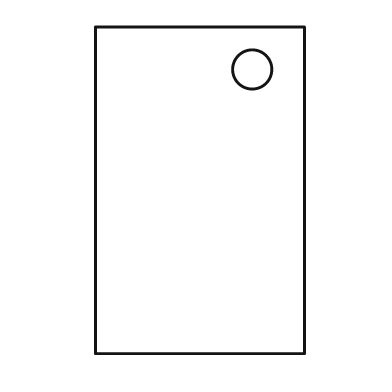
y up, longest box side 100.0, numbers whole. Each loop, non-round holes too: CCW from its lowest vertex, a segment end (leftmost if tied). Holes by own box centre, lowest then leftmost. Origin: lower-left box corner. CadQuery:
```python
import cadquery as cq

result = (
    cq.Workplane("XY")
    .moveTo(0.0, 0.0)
    .lineTo(64.0, 0.0)
    .lineTo(64.0, 100.0)
    .lineTo(0.0, 100.0)
    .close()
    .moveTo(48.0, 87.0)
    .circle(6.0)
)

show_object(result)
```